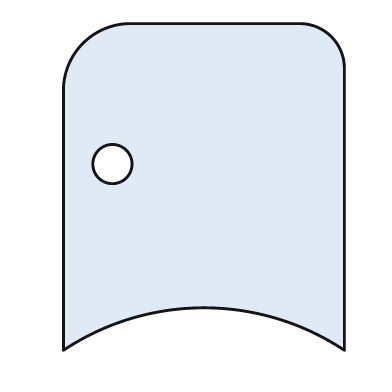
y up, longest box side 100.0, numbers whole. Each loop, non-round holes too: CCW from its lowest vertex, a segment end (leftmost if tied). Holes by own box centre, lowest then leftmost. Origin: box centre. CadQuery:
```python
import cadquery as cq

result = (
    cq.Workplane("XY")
    .moveTo(-43.0, -50.0)
    .threePointArc((0.0, -37.0), (43.0, -50.0))
    .lineTo(43.0, 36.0)
    .threePointArc((39.0, 46.0), (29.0, 50.0))
    .lineTo(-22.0, 50.0)
    .threePointArc((-37.0, 44.0), (-43.0, 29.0))
    .close()
    .moveTo(-28.0, 7.0)
    .circle(6.0)
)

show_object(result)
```